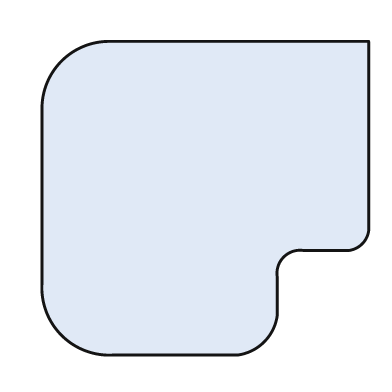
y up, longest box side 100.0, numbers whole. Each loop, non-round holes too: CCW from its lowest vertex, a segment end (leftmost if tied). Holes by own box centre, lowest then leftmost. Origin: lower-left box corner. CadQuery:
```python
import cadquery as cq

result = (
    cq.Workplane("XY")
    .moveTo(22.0, 0.0)
    .lineTo(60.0, 0.0)
    .threePointArc((68.0, 4.0), (72.0, 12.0))
    .lineTo(72.0, 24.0)
    .threePointArc((74.0, 30.0), (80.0, 32.0))
    .lineTo(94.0, 32.0)
    .threePointArc((98.0, 34.0), (100.0, 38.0))
    .lineTo(100.0, 96.0)
    .lineTo(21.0, 96.0)
    .threePointArc((6.0, 90.0), (0.0, 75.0))
    .lineTo(0.0, 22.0)
    .threePointArc((6.0, 6.0), (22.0, 0.0))
    .close()
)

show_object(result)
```